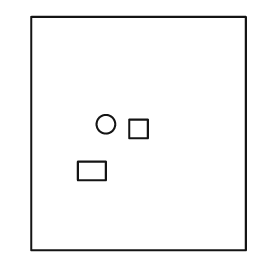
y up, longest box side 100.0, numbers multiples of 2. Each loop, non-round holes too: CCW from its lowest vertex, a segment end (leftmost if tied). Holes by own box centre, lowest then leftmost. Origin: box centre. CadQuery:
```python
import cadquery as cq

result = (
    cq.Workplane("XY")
    .moveTo(-46.0, -50.0)
    .lineTo(46.0, -50.0)
    .lineTo(46.0, 50.0)
    .lineTo(-46.0, 50.0)
    .close()
    .moveTo(-26.0, -20.0)
    .lineTo(-14.0, -20.0)
    .lineTo(-14.0, -12.0)
    .lineTo(-26.0, -12.0)
    .close()
    .moveTo(-4.0, -2.0)
    .lineTo(4.0, -2.0)
    .lineTo(4.0, 6.0)
    .lineTo(-4.0, 6.0)
    .close()
    .moveTo(-14.0, 4.0)
    .circle(4.0)
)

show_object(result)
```